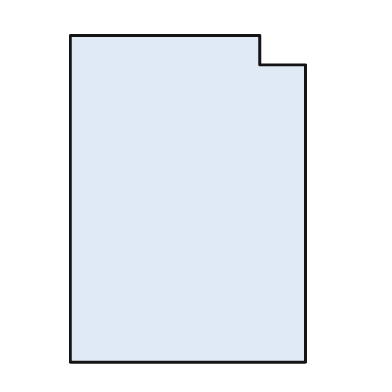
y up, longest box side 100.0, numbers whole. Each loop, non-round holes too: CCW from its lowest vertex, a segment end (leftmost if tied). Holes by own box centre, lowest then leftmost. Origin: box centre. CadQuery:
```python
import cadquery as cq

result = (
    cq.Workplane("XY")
    .moveTo(-36.0, -50.0)
    .lineTo(36.0, -50.0)
    .lineTo(36.0, 41.0)
    .lineTo(22.0, 41.0)
    .lineTo(22.0, 50.0)
    .lineTo(-36.0, 50.0)
    .close()
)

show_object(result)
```